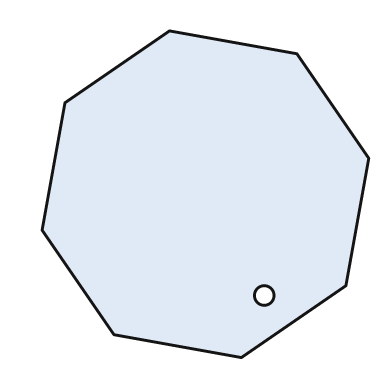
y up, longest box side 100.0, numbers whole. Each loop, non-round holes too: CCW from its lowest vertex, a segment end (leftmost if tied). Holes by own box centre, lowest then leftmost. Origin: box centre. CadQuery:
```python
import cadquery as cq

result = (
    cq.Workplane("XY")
    .moveTo(11.0, -50.0)
    .lineTo(43.0, -28.0)
    .lineTo(50.0, 11.0)
    .lineTo(28.0, 43.0)
    .lineTo(-11.0, 50.0)
    .lineTo(-43.0, 28.0)
    .lineTo(-50.0, -11.0)
    .lineTo(-28.0, -43.0)
    .close()
    .moveTo(18.0, -31.0)
    .circle(3.0)
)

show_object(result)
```